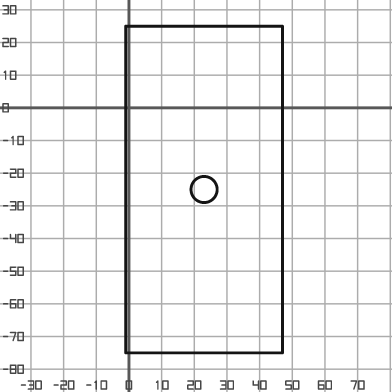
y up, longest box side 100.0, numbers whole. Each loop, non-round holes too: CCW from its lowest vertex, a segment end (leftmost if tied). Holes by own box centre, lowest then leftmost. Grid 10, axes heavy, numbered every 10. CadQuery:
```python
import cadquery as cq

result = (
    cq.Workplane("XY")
    .moveTo(-1.0, -75.0)
    .lineTo(47.0, -75.0)
    .lineTo(47.0, 25.0)
    .lineTo(-1.0, 25.0)
    .close()
    .moveTo(23.0, -25.0)
    .circle(4.0)
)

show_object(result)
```